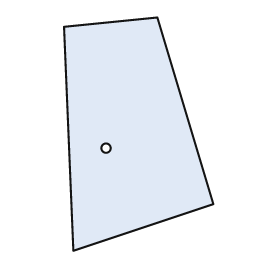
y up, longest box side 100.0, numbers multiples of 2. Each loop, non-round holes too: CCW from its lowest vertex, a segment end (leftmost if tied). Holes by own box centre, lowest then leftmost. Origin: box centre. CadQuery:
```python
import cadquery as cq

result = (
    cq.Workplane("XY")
    .moveTo(-28.0, -50.0)
    .lineTo(32.0, -30.0)
    .lineTo(8.0, 50.0)
    .lineTo(-32.0, 46.0)
    .close()
    .moveTo(-14.0, -6.0)
    .circle(2.0)
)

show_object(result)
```